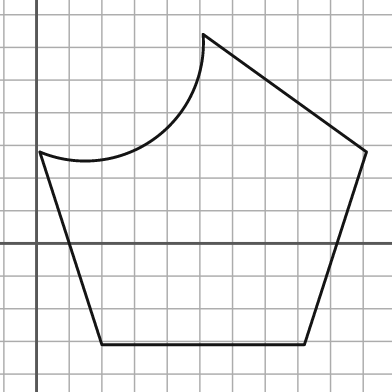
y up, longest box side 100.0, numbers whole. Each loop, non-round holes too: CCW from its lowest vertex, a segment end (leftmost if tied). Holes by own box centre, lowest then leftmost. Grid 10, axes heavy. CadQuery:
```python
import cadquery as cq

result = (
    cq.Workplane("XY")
    .moveTo(20.0, -31.0)
    .lineTo(82.0, -31.0)
    .lineTo(101.0, 28.0)
    .lineTo(51.0, 64.0)
    .threePointArc((36.0, 32.0), (1.0, 28.0))
    .close()
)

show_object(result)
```